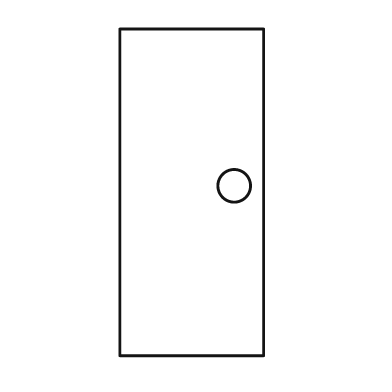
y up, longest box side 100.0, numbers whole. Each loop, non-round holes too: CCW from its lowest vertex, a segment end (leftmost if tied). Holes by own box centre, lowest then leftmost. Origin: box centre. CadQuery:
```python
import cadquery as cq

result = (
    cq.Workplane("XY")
    .moveTo(-22.0, -50.0)
    .lineTo(22.0, -50.0)
    .lineTo(22.0, 50.0)
    .lineTo(-22.0, 50.0)
    .close()
    .moveTo(13.0, 2.0)
    .circle(5.0)
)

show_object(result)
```